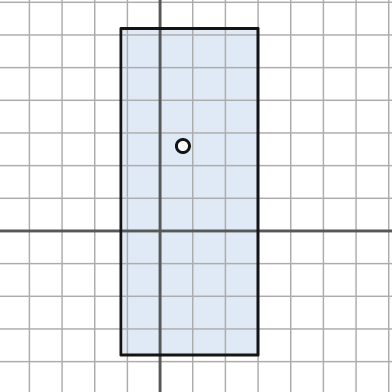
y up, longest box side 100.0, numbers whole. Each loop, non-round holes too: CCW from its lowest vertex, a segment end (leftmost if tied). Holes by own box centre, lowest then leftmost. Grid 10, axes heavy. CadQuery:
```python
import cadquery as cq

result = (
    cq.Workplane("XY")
    .moveTo(-12.0, -38.0)
    .lineTo(30.0, -38.0)
    .lineTo(30.0, 62.0)
    .lineTo(-12.0, 62.0)
    .close()
    .moveTo(7.0, 26.0)
    .circle(2.0)
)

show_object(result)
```